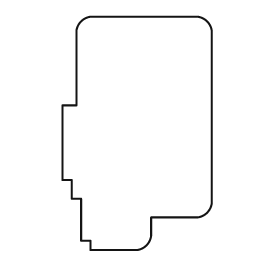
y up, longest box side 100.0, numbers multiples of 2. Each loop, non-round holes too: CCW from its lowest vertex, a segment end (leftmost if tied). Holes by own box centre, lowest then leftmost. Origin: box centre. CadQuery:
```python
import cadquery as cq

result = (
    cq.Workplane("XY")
    .moveTo(-20.0, -50.0)
    .lineTo(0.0, -50.0)
    .threePointArc((4.0, -48.0), (6.0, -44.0))
    .lineTo(6.0, -36.0)
    .lineTo(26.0, -36.0)
    .threePointArc((30.0, -34.0), (32.0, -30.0))
    .lineTo(32.0, 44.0)
    .threePointArc((30.0, 48.0), (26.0, 50.0))
    .lineTo(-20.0, 50.0)
    .threePointArc((-24.0, 48.0), (-26.0, 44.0))
    .lineTo(-26.0, 12.0)
    .lineTo(-32.0, 12.0)
    .lineTo(-32.0, -20.0)
    .lineTo(-28.0, -20.0)
    .lineTo(-28.0, -28.0)
    .lineTo(-24.0, -28.0)
    .lineTo(-24.0, -46.0)
    .lineTo(-20.0, -46.0)
    .close()
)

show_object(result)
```